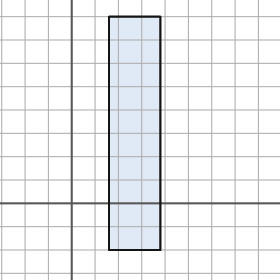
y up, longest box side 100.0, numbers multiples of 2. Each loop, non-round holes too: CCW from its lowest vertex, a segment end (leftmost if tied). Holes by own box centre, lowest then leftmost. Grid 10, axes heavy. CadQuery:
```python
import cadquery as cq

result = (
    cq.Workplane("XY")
    .moveTo(16.0, -20.0)
    .lineTo(38.0, -20.0)
    .lineTo(38.0, 80.0)
    .lineTo(16.0, 80.0)
    .close()
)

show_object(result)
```